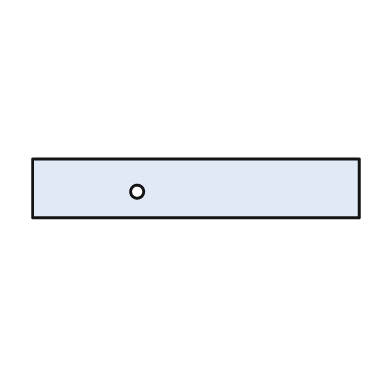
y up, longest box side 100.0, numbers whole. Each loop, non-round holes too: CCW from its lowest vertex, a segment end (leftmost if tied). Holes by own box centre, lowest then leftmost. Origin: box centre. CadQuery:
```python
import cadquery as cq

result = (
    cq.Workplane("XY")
    .moveTo(-50.0, -9.0)
    .lineTo(50.0, -9.0)
    .lineTo(50.0, 9.0)
    .lineTo(-50.0, 9.0)
    .close()
    .moveTo(-18.0, -1.0)
    .circle(2.0)
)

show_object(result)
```